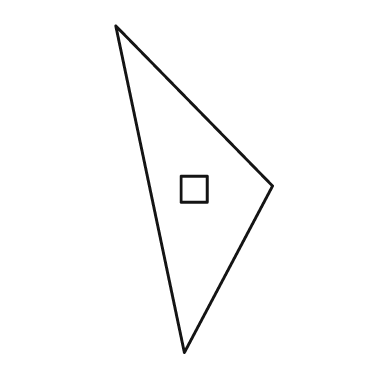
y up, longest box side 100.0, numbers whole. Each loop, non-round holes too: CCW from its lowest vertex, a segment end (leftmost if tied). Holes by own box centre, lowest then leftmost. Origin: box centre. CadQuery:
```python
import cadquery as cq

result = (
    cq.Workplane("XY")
    .moveTo(-3.0, -50.0)
    .lineTo(24.0, 1.0)
    .lineTo(-24.0, 50.0)
    .close()
    .moveTo(-4.0, -4.0)
    .lineTo(4.0, -4.0)
    .lineTo(4.0, 4.0)
    .lineTo(-4.0, 4.0)
    .close()
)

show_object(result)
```